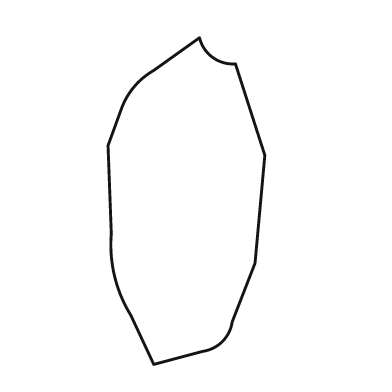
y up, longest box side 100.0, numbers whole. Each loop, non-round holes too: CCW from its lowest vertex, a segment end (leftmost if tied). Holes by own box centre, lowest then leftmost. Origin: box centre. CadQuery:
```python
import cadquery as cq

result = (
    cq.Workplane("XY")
    .moveTo(-10.0, -50.0)
    .lineTo(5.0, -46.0)
    .threePointArc((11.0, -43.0), (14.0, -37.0))
    .lineTo(21.0, -19.0)
    .lineTo(24.0, 14.0)
    .lineTo(15.0, 42.0)
    .threePointArc((8.0, 44.0), (4.0, 50.0))
    .lineTo(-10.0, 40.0)
    .threePointArc((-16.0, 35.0), (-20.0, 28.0))
    .lineTo(-24.0, 17.0)
    .lineTo(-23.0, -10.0)
    .threePointArc((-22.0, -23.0), (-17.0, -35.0))
    .close()
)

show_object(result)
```